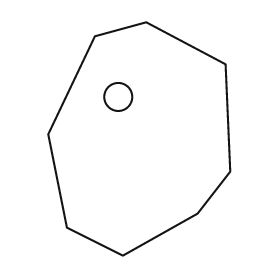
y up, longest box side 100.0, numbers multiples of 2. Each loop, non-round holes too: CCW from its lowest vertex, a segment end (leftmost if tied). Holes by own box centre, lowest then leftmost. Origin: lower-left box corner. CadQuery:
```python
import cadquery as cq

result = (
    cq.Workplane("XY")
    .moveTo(32.0, 0.0)
    .lineTo(64.0, 18.0)
    .lineTo(78.0, 36.0)
    .lineTo(76.0, 82.0)
    .lineTo(42.0, 100.0)
    .lineTo(20.0, 94.0)
    .lineTo(0.0, 52.0)
    .lineTo(8.0, 12.0)
    .close()
    .moveTo(30.0, 68.0)
    .circle(6.0)
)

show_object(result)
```